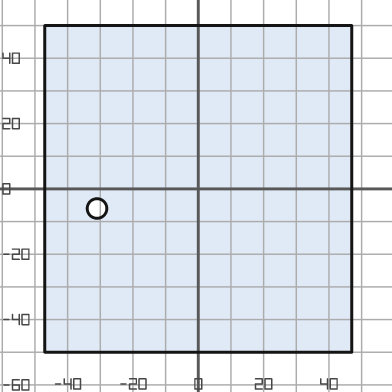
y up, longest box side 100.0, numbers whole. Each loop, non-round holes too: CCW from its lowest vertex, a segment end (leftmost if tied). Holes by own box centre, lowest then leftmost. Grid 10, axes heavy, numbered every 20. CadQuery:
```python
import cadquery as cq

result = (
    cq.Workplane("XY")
    .moveTo(-47.0, -50.0)
    .lineTo(47.0, -50.0)
    .lineTo(47.0, 50.0)
    .lineTo(-47.0, 50.0)
    .close()
    .moveTo(-31.0, -6.0)
    .circle(3.0)
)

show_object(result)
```